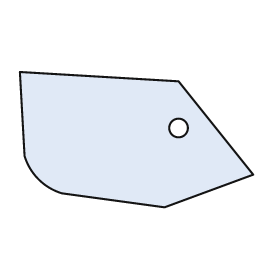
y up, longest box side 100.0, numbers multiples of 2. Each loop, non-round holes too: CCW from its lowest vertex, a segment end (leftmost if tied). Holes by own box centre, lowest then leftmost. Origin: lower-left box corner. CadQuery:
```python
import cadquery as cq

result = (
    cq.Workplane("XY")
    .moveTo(62.0, 0.0)
    .lineTo(100.0, 14.0)
    .lineTo(68.0, 54.0)
    .lineTo(0.0, 58.0)
    .lineTo(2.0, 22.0)
    .threePointArc((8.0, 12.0), (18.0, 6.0))
    .close()
    .moveTo(68.0, 34.0)
    .circle(4.0)
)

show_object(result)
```